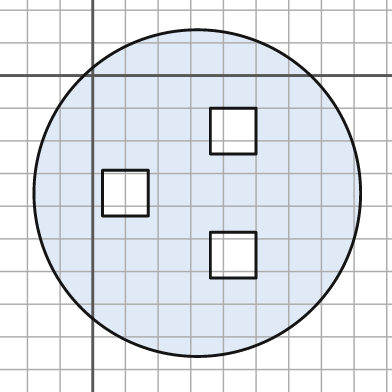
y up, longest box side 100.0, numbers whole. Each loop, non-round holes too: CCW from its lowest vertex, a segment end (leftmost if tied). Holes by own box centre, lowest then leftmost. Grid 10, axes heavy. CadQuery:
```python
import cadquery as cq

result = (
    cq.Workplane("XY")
    .moveTo(32.0, -36.0)
    .circle(50.0)
    .moveTo(36.0, -62.0)
    .lineTo(50.0, -62.0)
    .lineTo(50.0, -48.0)
    .lineTo(36.0, -48.0)
    .close()
    .moveTo(3.0, -43.0)
    .lineTo(17.0, -43.0)
    .lineTo(17.0, -29.0)
    .lineTo(3.0, -29.0)
    .close()
    .moveTo(36.0, -24.0)
    .lineTo(50.0, -24.0)
    .lineTo(50.0, -10.0)
    .lineTo(36.0, -10.0)
    .close()
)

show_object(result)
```